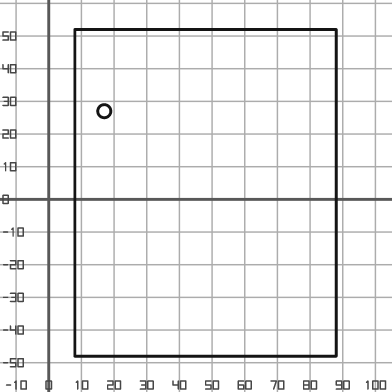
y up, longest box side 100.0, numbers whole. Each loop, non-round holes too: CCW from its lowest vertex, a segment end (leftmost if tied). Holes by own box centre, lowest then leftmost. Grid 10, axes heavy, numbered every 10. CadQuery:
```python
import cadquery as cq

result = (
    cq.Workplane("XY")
    .moveTo(8.0, -48.0)
    .lineTo(88.0, -48.0)
    .lineTo(88.0, 52.0)
    .lineTo(8.0, 52.0)
    .close()
    .moveTo(17.0, 27.0)
    .circle(2.0)
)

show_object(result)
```